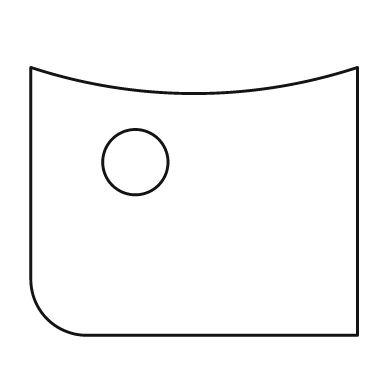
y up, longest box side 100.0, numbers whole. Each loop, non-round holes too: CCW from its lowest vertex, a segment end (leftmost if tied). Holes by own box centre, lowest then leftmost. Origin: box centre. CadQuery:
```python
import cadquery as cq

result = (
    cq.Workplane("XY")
    .moveTo(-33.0, -41.0)
    .lineTo(50.0, -41.0)
    .lineTo(50.0, 41.0)
    .threePointArc((0.0, 33.0), (-50.0, 41.0))
    .lineTo(-50.0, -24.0)
    .threePointArc((-45.0, -36.0), (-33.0, -41.0))
    .close()
    .moveTo(-18.0, 12.0)
    .circle(10.0)
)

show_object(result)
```